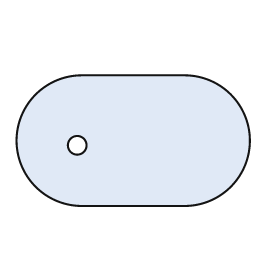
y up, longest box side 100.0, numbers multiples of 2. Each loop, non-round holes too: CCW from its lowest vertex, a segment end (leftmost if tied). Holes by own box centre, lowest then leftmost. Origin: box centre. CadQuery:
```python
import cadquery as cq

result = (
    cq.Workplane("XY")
    .moveTo(-22.0, -28.0)
    .lineTo(22.0, -28.0)
    .threePointArc((50.0, 0.0), (22.0, 28.0))
    .lineTo(-22.0, 28.0)
    .threePointArc((-50.0, 0.0), (-22.0, -28.0))
    .close()
    .moveTo(-24.0, -2.0)
    .circle(4.0)
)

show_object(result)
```